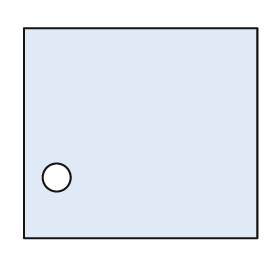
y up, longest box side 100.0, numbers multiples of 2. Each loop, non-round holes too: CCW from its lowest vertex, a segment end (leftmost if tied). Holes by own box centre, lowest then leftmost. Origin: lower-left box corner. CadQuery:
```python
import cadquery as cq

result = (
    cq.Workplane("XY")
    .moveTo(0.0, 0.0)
    .lineTo(100.0, 0.0)
    .lineTo(100.0, 90.0)
    .lineTo(0.0, 90.0)
    .close()
    .moveTo(14.0, 26.0)
    .circle(6.0)
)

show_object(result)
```